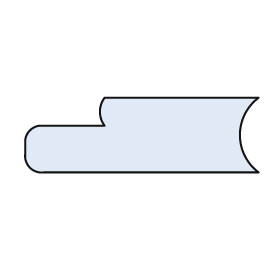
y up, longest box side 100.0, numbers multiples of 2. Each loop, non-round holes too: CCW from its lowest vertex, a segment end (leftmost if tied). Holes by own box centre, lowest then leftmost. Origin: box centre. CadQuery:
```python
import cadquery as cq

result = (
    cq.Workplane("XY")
    .moveTo(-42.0, -16.0)
    .lineTo(50.0, -16.0)
    .threePointArc((42.0, 0.0), (50.0, 16.0))
    .lineTo(-16.0, 16.0)
    .threePointArc((-18.0, 10.0), (-16.0, 4.0))
    .lineTo(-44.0, 4.0)
    .threePointArc((-48.0, 2.0), (-50.0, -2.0))
    .lineTo(-50.0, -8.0)
    .threePointArc((-48.0, -14.0), (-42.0, -16.0))
    .close()
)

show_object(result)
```